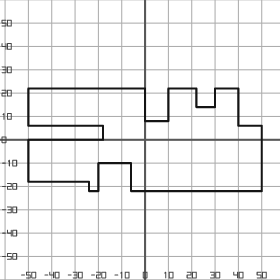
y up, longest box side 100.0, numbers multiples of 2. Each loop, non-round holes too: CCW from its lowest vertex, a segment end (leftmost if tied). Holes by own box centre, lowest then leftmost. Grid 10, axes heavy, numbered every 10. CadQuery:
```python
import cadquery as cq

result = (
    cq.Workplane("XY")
    .moveTo(-24.0, -22.0)
    .lineTo(-20.0, -22.0)
    .lineTo(-20.0, -10.0)
    .lineTo(-6.0, -10.0)
    .lineTo(-6.0, -22.0)
    .lineTo(50.0, -22.0)
    .lineTo(50.0, 6.0)
    .lineTo(40.0, 6.0)
    .lineTo(40.0, 22.0)
    .lineTo(30.0, 22.0)
    .lineTo(30.0, 14.0)
    .lineTo(22.0, 14.0)
    .lineTo(22.0, 22.0)
    .lineTo(10.0, 22.0)
    .lineTo(10.0, 8.0)
    .lineTo(0.0, 8.0)
    .lineTo(0.0, 22.0)
    .lineTo(-50.0, 22.0)
    .lineTo(-50.0, 6.0)
    .lineTo(-18.0, 6.0)
    .lineTo(-18.0, 0.0)
    .lineTo(-50.0, 0.0)
    .lineTo(-50.0, -18.0)
    .lineTo(-24.0, -18.0)
    .close()
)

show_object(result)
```